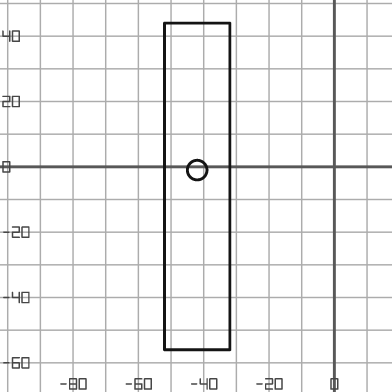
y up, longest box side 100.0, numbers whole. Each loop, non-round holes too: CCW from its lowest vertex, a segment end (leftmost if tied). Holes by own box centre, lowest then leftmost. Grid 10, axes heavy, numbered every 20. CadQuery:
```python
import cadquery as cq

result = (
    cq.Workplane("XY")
    .moveTo(-52.0, -56.0)
    .lineTo(-32.0, -56.0)
    .lineTo(-32.0, 44.0)
    .lineTo(-52.0, 44.0)
    .close()
    .moveTo(-42.0, -1.0)
    .circle(3.0)
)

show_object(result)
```